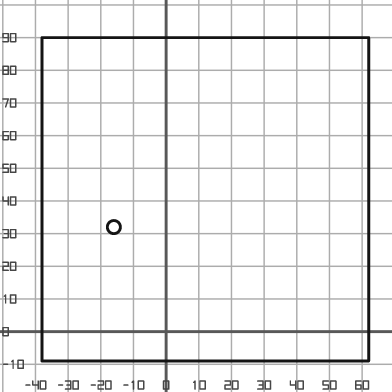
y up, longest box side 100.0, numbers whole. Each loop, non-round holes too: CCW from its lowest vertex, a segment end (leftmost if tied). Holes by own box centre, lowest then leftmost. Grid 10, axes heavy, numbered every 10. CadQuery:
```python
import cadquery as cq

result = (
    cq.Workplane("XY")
    .moveTo(-38.0, -9.0)
    .lineTo(62.0, -9.0)
    .lineTo(62.0, 90.0)
    .lineTo(-38.0, 90.0)
    .close()
    .moveTo(-16.0, 32.0)
    .circle(2.0)
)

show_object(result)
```